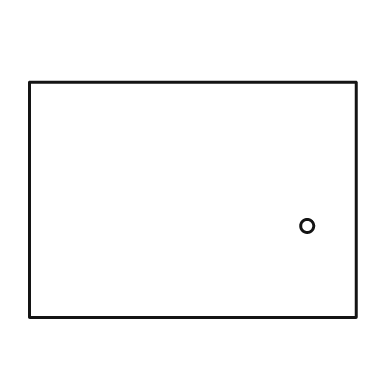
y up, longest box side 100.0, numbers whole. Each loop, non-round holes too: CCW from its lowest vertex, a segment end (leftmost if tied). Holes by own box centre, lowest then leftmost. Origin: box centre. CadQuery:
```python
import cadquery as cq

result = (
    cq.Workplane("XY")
    .moveTo(-50.0, -36.0)
    .lineTo(50.0, -36.0)
    .lineTo(50.0, 36.0)
    .lineTo(-50.0, 36.0)
    .close()
    .moveTo(35.0, -8.0)
    .circle(2.0)
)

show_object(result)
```